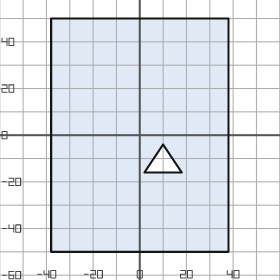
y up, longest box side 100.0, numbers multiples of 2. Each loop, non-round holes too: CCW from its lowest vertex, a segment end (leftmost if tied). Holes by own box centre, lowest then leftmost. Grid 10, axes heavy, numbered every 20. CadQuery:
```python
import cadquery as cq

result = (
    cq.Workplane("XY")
    .moveTo(-38.0, -50.0)
    .lineTo(38.0, -50.0)
    .lineTo(38.0, 50.0)
    .lineTo(-38.0, 50.0)
    .close()
    .moveTo(2.0, -16.0)
    .lineTo(18.0, -16.0)
    .lineTo(10.0, -4.0)
    .close()
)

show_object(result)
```